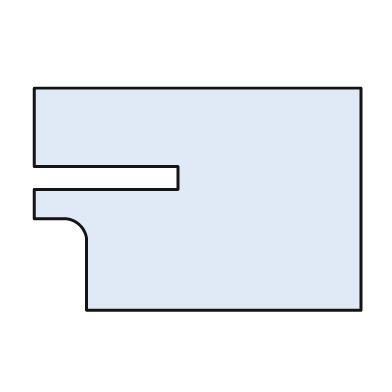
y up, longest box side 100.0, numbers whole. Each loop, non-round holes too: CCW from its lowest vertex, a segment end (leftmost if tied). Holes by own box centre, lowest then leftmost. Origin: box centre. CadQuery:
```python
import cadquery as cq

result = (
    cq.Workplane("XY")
    .moveTo(-34.0, -34.0)
    .lineTo(50.0, -34.0)
    .lineTo(50.0, 34.0)
    .lineTo(-50.0, 34.0)
    .lineTo(-50.0, 10.0)
    .lineTo(-6.0, 10.0)
    .lineTo(-6.0, 3.0)
    .lineTo(-50.0, 3.0)
    .lineTo(-50.0, -6.0)
    .lineTo(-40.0, -6.0)
    .threePointArc((-36.0, -8.0), (-34.0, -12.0))
    .close()
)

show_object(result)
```